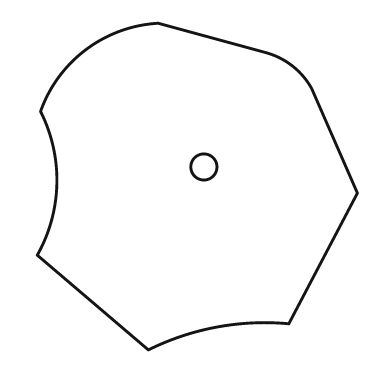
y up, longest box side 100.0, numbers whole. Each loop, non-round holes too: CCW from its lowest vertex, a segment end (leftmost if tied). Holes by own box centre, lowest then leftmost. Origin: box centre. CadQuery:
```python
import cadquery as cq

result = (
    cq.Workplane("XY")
    .moveTo(-15.0, -50.0)
    .threePointArc((6.0, -43.0), (28.0, -42.0))
    .lineTo(49.0, -2.0)
    .lineTo(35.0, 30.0)
    .threePointArc((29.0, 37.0), (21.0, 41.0))
    .lineTo(-12.0, 50.0)
    .threePointArc((-34.0, 42.0), (-48.0, 23.0))
    .threePointArc((-43.0, 1.0), (-49.0, -21.0))
    .close()
    .moveTo(2.0, 6.0)
    .circle(4.0)
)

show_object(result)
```